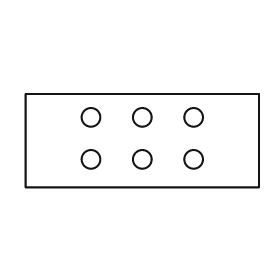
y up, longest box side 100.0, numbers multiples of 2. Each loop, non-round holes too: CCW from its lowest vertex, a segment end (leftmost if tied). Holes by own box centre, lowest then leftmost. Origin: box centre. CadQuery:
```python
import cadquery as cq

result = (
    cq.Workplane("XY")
    .moveTo(-50.0, -20.0)
    .lineTo(50.0, -20.0)
    .lineTo(50.0, 20.0)
    .lineTo(-50.0, 20.0)
    .close()
    .moveTo(-22.0, -8.0)
    .circle(4.0)
    .moveTo(0.0, -8.0)
    .circle(4.0)
    .moveTo(22.0, -8.0)
    .circle(4.0)
    .moveTo(-22.0, 10.0)
    .circle(4.0)
    .moveTo(0.0, 10.0)
    .circle(4.0)
    .moveTo(22.0, 10.0)
    .circle(4.0)
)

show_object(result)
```